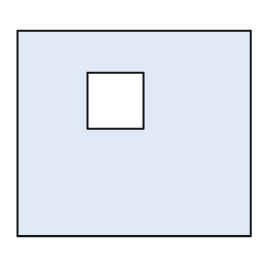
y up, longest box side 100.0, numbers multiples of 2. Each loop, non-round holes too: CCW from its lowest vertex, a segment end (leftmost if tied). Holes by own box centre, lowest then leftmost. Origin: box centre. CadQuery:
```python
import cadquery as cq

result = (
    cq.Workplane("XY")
    .moveTo(-50.0, -44.0)
    .lineTo(50.0, -44.0)
    .lineTo(50.0, 44.0)
    .lineTo(-50.0, 44.0)
    .close()
    .moveTo(-20.0, 2.0)
    .lineTo(4.0, 2.0)
    .lineTo(4.0, 26.0)
    .lineTo(-20.0, 26.0)
    .close()
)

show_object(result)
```